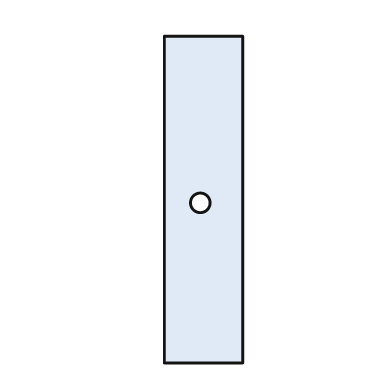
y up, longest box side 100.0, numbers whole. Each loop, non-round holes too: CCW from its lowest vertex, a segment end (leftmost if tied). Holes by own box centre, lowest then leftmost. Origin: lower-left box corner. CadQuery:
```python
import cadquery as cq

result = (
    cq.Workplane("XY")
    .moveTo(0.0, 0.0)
    .lineTo(24.0, 0.0)
    .lineTo(24.0, 100.0)
    .lineTo(0.0, 100.0)
    .close()
    .moveTo(11.0, 49.0)
    .circle(3.0)
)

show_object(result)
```